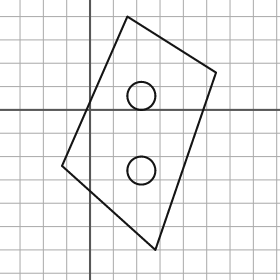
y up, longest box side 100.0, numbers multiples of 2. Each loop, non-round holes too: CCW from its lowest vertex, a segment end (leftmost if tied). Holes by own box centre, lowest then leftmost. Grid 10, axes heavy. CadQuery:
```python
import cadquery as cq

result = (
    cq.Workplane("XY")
    .moveTo(28.0, -60.0)
    .lineTo(54.0, 16.0)
    .lineTo(16.0, 40.0)
    .lineTo(-12.0, -24.0)
    .close()
    .moveTo(22.0, -26.0)
    .circle(6.0)
    .moveTo(22.0, 6.0)
    .circle(6.0)
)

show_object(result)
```